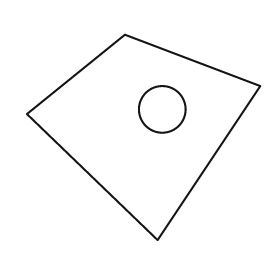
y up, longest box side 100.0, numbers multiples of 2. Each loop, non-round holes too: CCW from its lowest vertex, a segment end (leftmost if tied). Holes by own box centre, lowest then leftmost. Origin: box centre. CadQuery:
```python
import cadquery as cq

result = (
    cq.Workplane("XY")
    .moveTo(6.0, -44.0)
    .lineTo(50.0, 22.0)
    .lineTo(-8.0, 44.0)
    .lineTo(-50.0, 10.0)
    .close()
    .moveTo(8.0, 12.0)
    .circle(10.0)
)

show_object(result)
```